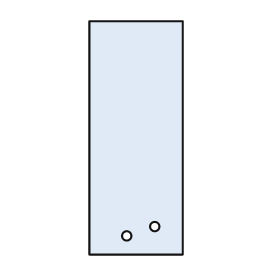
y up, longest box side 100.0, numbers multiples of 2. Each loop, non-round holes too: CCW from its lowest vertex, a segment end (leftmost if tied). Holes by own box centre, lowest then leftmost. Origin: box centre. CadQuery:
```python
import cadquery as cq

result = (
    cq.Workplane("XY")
    .moveTo(-20.0, -50.0)
    .lineTo(20.0, -50.0)
    .lineTo(20.0, 50.0)
    .lineTo(-20.0, 50.0)
    .close()
    .moveTo(-4.0, -42.0)
    .circle(2.0)
    .moveTo(8.0, -38.0)
    .circle(2.0)
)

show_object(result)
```